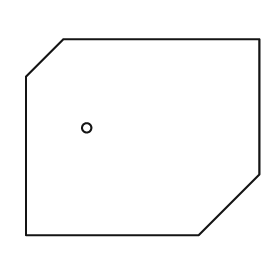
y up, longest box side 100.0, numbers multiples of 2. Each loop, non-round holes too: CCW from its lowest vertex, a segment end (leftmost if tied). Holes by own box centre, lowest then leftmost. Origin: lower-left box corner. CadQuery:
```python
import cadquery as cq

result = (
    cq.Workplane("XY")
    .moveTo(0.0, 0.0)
    .lineTo(74.0, 0.0)
    .lineTo(100.0, 26.0)
    .lineTo(100.0, 84.0)
    .lineTo(16.0, 84.0)
    .lineTo(0.0, 68.0)
    .close()
    .moveTo(26.0, 46.0)
    .circle(2.0)
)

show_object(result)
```